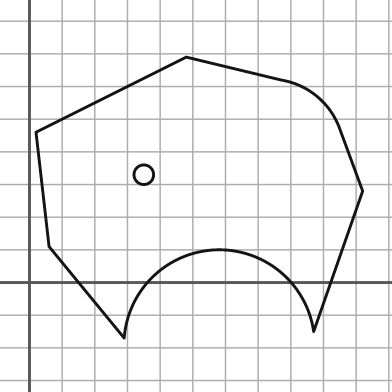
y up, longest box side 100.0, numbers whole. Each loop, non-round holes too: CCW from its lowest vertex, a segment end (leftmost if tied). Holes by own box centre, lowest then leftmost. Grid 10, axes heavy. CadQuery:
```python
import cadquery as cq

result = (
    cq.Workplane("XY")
    .moveTo(29.0, -17.0)
    .threePointArc((57.0, 10.0), (87.0, -15.0))
    .lineTo(102.0, 28.0)
    .lineTo(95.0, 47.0)
    .threePointArc((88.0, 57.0), (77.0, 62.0))
    .lineTo(48.0, 69.0)
    .lineTo(2.0, 46.0)
    .lineTo(6.0, 11.0)
    .close()
    .moveTo(35.0, 33.0)
    .circle(3.0)
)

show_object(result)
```